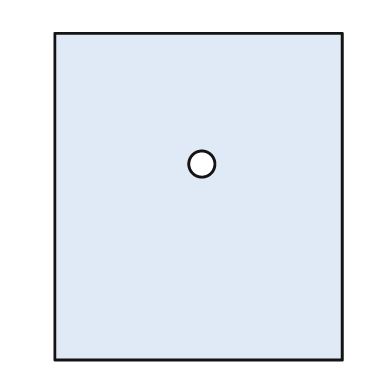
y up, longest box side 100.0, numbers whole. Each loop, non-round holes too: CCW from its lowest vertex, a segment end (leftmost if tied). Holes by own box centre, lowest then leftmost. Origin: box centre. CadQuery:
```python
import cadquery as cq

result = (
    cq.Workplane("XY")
    .moveTo(-44.0, -50.0)
    .lineTo(44.0, -50.0)
    .lineTo(44.0, 50.0)
    .lineTo(-44.0, 50.0)
    .close()
    .moveTo(1.0, 10.0)
    .circle(4.0)
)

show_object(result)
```